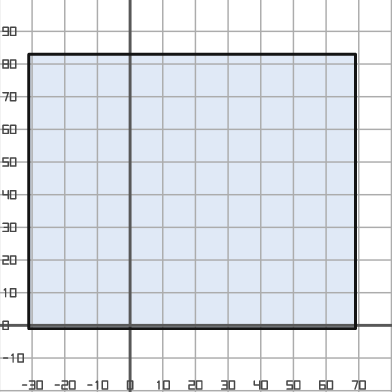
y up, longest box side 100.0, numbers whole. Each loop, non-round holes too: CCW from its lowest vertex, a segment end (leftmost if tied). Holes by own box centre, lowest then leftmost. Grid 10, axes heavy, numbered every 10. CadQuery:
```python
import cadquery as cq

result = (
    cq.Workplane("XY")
    .moveTo(-31.0, -1.0)
    .lineTo(69.0, -1.0)
    .lineTo(69.0, 83.0)
    .lineTo(-31.0, 83.0)
    .close()
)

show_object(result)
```